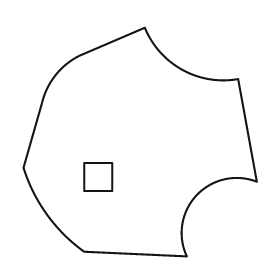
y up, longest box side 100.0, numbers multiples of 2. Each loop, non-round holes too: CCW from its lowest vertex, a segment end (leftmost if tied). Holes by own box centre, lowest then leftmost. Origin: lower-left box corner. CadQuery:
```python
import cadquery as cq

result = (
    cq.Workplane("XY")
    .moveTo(70.0, 0.0)
    .threePointArc((74.0, 26.0), (100.0, 32.0))
    .lineTo(92.0, 76.0)
    .threePointArc((68.0, 80.0), (52.0, 98.0))
    .lineTo(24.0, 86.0)
    .threePointArc((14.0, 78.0), (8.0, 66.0))
    .lineTo(0.0, 38.0)
    .threePointArc((10.0, 18.0), (26.0, 2.0))
    .close()
    .moveTo(26.0, 28.0)
    .lineTo(38.0, 28.0)
    .lineTo(38.0, 40.0)
    .lineTo(26.0, 40.0)
    .close()
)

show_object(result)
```